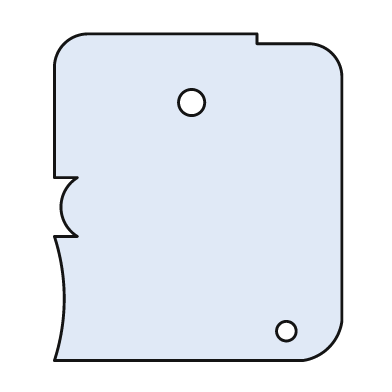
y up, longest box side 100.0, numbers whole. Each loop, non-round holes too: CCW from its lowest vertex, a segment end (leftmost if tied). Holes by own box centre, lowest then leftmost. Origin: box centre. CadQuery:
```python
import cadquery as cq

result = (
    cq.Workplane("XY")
    .moveTo(-44.0, -50.0)
    .lineTo(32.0, -50.0)
    .threePointArc((40.0, -46.0), (44.0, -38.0))
    .lineTo(44.0, 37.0)
    .threePointArc((41.0, 44.0), (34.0, 47.0))
    .lineTo(18.0, 47.0)
    .lineTo(18.0, 50.0)
    .lineTo(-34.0, 50.0)
    .threePointArc((-41.0, 47.0), (-44.0, 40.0))
    .lineTo(-44.0, 6.0)
    .lineTo(-37.0, 6.0)
    .threePointArc((-42.0, -3.0), (-37.0, -12.0))
    .lineTo(-44.0, -12.0)
    .threePointArc((-41.0, -31.0), (-44.0, -50.0))
    .close()
    .moveTo(27.0, -41.0)
    .circle(3.0)
    .moveTo(-2.0, 29.0)
    .circle(4.0)
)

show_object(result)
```